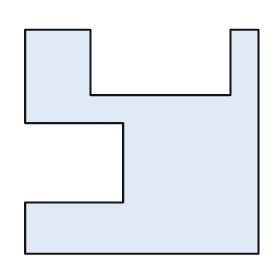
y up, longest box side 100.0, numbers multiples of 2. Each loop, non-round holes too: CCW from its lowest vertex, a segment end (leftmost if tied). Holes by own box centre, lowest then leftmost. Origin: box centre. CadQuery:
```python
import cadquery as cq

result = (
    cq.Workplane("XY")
    .moveTo(-50.0, -48.0)
    .lineTo(50.0, -48.0)
    .lineTo(50.0, 48.0)
    .lineTo(38.0, 48.0)
    .lineTo(38.0, 20.0)
    .lineTo(-22.0, 20.0)
    .lineTo(-22.0, 48.0)
    .lineTo(-50.0, 48.0)
    .lineTo(-50.0, 8.0)
    .lineTo(-8.0, 8.0)
    .lineTo(-8.0, -26.0)
    .lineTo(-50.0, -26.0)
    .close()
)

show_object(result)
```